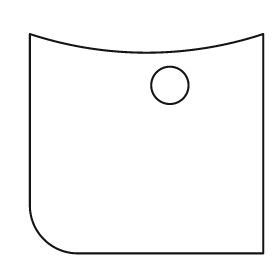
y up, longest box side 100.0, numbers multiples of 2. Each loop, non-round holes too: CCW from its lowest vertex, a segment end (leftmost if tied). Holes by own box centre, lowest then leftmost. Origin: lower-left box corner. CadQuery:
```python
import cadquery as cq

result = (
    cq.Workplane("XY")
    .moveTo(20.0, 0.0)
    .lineTo(100.0, 0.0)
    .lineTo(100.0, 94.0)
    .threePointArc((50.0, 86.0), (0.0, 94.0))
    .lineTo(0.0, 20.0)
    .threePointArc((6.0, 6.0), (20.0, 0.0))
    .close()
    .moveTo(60.0, 72.0)
    .circle(8.0)
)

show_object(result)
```